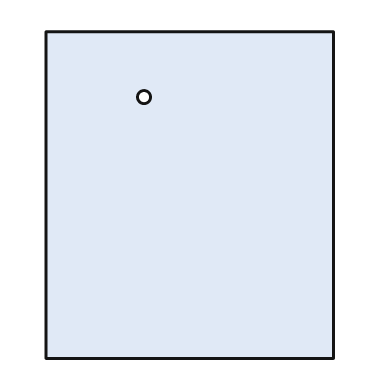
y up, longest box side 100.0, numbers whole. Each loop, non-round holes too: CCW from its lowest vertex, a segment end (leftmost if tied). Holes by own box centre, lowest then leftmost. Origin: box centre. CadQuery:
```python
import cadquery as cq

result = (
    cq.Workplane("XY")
    .moveTo(-44.0, -50.0)
    .lineTo(44.0, -50.0)
    .lineTo(44.0, 50.0)
    .lineTo(-44.0, 50.0)
    .close()
    .moveTo(-14.0, 30.0)
    .circle(2.0)
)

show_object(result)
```